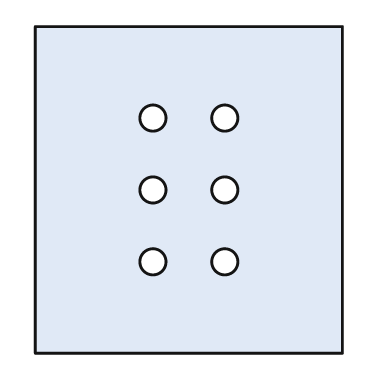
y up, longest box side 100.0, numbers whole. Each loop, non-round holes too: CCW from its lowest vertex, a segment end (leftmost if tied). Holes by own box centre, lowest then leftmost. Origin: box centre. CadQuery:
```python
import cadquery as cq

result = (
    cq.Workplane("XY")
    .moveTo(-47.0, -50.0)
    .lineTo(47.0, -50.0)
    .lineTo(47.0, 50.0)
    .lineTo(-47.0, 50.0)
    .close()
    .moveTo(-11.0, -22.0)
    .circle(4.0)
    .moveTo(11.0, -22.0)
    .circle(4.0)
    .moveTo(-11.0, 0.0)
    .circle(4.0)
    .moveTo(11.0, 0.0)
    .circle(4.0)
    .moveTo(-11.0, 22.0)
    .circle(4.0)
    .moveTo(11.0, 22.0)
    .circle(4.0)
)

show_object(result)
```